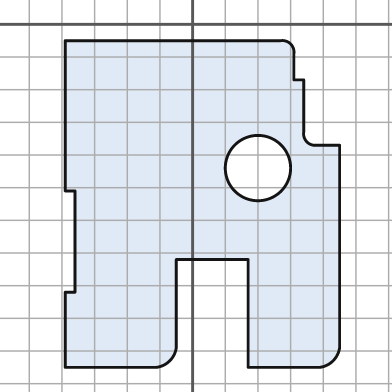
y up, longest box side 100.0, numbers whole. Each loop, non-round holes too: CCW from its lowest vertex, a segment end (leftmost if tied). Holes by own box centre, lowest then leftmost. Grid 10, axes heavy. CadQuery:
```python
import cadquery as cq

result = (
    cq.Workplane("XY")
    .moveTo(-39.0, -105.0)
    .lineTo(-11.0, -105.0)
    .threePointArc((-7.0, -103.0), (-5.0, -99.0))
    .lineTo(-5.0, -72.0)
    .lineTo(17.0, -72.0)
    .lineTo(17.0, -105.0)
    .lineTo(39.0, -105.0)
    .threePointArc((43.0, -103.0), (45.0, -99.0))
    .lineTo(45.0, -37.0)
    .lineTo(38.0, -37.0)
    .threePointArc((35.0, -36.0), (34.0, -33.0))
    .lineTo(34.0, -17.0)
    .lineTo(31.0, -17.0)
    .lineTo(31.0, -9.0)
    .threePointArc((30.0, -6.0), (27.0, -5.0))
    .lineTo(-39.0, -5.0)
    .lineTo(-39.0, -51.0)
    .lineTo(-36.0, -51.0)
    .lineTo(-36.0, -82.0)
    .lineTo(-39.0, -82.0)
    .close()
    .moveTo(20.0, -44.0)
    .circle(10.0)
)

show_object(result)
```